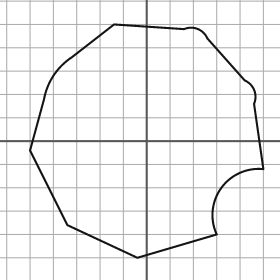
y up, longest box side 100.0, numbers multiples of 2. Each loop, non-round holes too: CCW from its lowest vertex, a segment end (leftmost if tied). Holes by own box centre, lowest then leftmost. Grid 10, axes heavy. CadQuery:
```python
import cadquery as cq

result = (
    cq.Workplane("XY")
    .moveTo(-4.0, -50.0)
    .lineTo(30.0, -40.0)
    .threePointArc((32.0, -20.0), (50.0, -12.0))
    .lineTo(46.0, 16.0)
    .threePointArc((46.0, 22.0), (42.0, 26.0))
    .lineTo(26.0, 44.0)
    .threePointArc((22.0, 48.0), (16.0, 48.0))
    .lineTo(-14.0, 50.0)
    .lineTo(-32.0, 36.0)
    .threePointArc((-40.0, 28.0), (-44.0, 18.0))
    .lineTo(-50.0, -4.0)
    .lineTo(-34.0, -36.0)
    .close()
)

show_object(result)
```